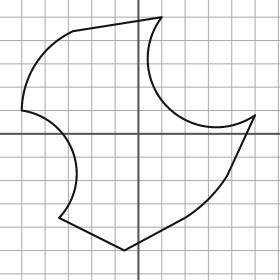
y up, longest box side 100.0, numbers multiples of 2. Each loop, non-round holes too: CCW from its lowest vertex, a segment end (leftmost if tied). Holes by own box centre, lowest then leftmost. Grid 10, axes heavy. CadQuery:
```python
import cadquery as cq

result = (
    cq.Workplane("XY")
    .moveTo(-6.0, -50.0)
    .lineTo(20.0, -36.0)
    .threePointArc((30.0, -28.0), (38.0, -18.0))
    .lineTo(50.0, 8.0)
    .threePointArc((12.0, 12.0), (10.0, 50.0))
    .lineTo(-28.0, 44.0)
    .threePointArc((-44.0, 30.0), (-50.0, 10.0))
    .threePointArc((-28.0, -8.0), (-34.0, -36.0))
    .close()
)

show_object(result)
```